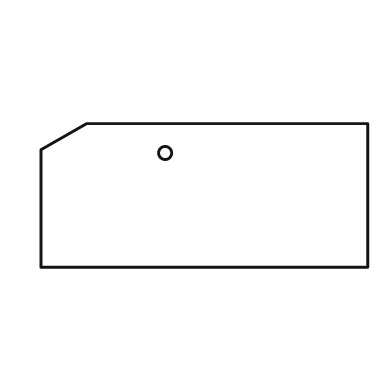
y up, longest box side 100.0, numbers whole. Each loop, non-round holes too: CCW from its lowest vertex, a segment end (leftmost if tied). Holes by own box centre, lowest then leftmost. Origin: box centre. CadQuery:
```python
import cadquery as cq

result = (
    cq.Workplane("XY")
    .moveTo(-50.0, -22.0)
    .lineTo(50.0, -22.0)
    .lineTo(50.0, 22.0)
    .lineTo(-36.0, 22.0)
    .lineTo(-50.0, 14.0)
    .close()
    .moveTo(-12.0, 13.0)
    .circle(2.0)
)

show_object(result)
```